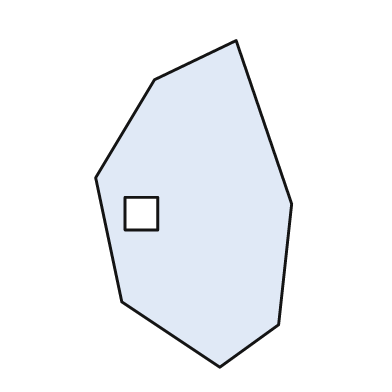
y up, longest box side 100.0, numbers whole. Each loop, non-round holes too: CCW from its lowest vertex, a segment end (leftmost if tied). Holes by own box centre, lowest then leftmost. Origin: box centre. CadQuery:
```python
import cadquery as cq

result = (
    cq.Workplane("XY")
    .moveTo(8.0, -50.0)
    .lineTo(26.0, -37.0)
    .lineTo(30.0, 0.0)
    .lineTo(13.0, 50.0)
    .lineTo(-12.0, 38.0)
    .lineTo(-30.0, 8.0)
    .lineTo(-22.0, -30.0)
    .close()
    .moveTo(-21.0, -8.0)
    .lineTo(-11.0, -8.0)
    .lineTo(-11.0, 2.0)
    .lineTo(-21.0, 2.0)
    .close()
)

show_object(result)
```